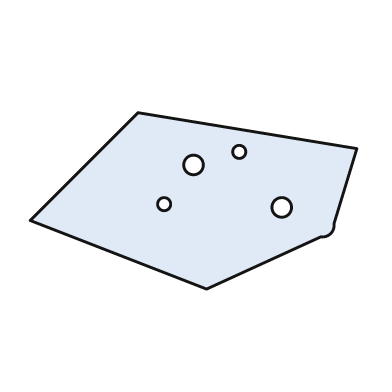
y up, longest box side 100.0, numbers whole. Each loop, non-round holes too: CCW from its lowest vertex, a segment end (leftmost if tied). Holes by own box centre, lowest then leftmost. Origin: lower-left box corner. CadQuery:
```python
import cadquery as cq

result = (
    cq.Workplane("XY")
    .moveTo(54.0, 0.0)
    .lineTo(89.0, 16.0)
    .threePointArc((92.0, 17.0), (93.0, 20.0))
    .lineTo(100.0, 43.0)
    .lineTo(33.0, 54.0)
    .lineTo(0.0, 21.0)
    .close()
    .moveTo(77.0, 25.0)
    .circle(3.0)
    .moveTo(41.0, 26.0)
    .circle(2.0)
    .moveTo(50.0, 38.0)
    .circle(3.0)
    .moveTo(64.0, 42.0)
    .circle(2.0)
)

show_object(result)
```